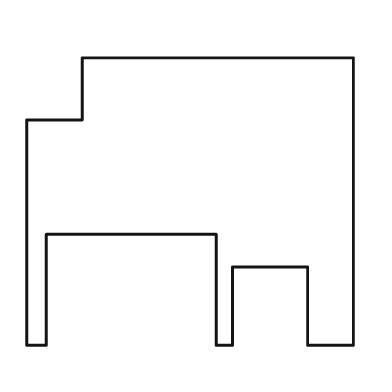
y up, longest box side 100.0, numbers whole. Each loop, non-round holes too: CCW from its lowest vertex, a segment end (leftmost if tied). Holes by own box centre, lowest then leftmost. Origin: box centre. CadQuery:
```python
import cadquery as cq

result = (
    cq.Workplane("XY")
    .moveTo(-50.0, -44.0)
    .lineTo(-44.0, -44.0)
    .lineTo(-44.0, -10.0)
    .lineTo(8.0, -10.0)
    .lineTo(8.0, -44.0)
    .lineTo(13.0, -44.0)
    .lineTo(13.0, -20.0)
    .lineTo(36.0, -20.0)
    .lineTo(36.0, -44.0)
    .lineTo(50.0, -44.0)
    .lineTo(50.0, 44.0)
    .lineTo(-33.0, 44.0)
    .lineTo(-33.0, 25.0)
    .lineTo(-50.0, 25.0)
    .close()
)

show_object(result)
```